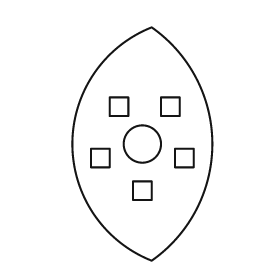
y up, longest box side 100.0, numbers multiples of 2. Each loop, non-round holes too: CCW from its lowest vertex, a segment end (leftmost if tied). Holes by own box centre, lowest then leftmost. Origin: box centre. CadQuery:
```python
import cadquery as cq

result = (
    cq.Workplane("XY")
    .moveTo(4.0, -50.0)
    .threePointArc((30.0, 0.0), (4.0, 50.0))
    .threePointArc((-30.0, 0.0), (4.0, -50.0))
    .close()
    .moveTo(-4.0, -24.0)
    .lineTo(4.0, -24.0)
    .lineTo(4.0, -16.0)
    .lineTo(-4.0, -16.0)
    .close()
    .moveTo(-22.0, -10.0)
    .lineTo(-14.0, -10.0)
    .lineTo(-14.0, -2.0)
    .lineTo(-22.0, -2.0)
    .close()
    .moveTo(14.0, -10.0)
    .lineTo(22.0, -10.0)
    .lineTo(22.0, -2.0)
    .lineTo(14.0, -2.0)
    .close()
    .moveTo(0.0, 0.0)
    .circle(8.0)
    .moveTo(-14.0, 12.0)
    .lineTo(-6.0, 12.0)
    .lineTo(-6.0, 20.0)
    .lineTo(-14.0, 20.0)
    .close()
    .moveTo(8.0, 12.0)
    .lineTo(16.0, 12.0)
    .lineTo(16.0, 20.0)
    .lineTo(8.0, 20.0)
    .close()
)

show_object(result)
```